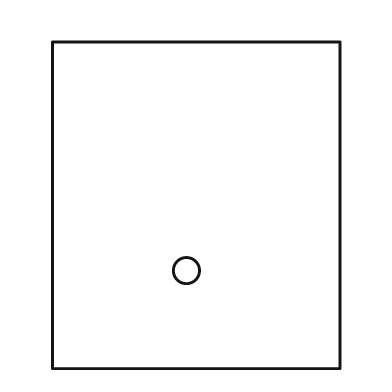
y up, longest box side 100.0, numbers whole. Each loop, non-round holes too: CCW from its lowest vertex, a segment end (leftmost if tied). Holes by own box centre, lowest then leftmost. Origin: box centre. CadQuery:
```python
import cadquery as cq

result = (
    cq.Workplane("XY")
    .moveTo(-44.0, -50.0)
    .lineTo(44.0, -50.0)
    .lineTo(44.0, 50.0)
    .lineTo(-44.0, 50.0)
    .close()
    .moveTo(-3.0, -20.0)
    .circle(4.0)
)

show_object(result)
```